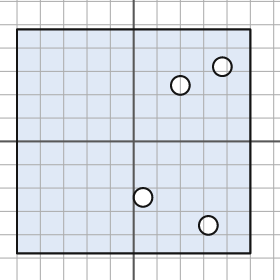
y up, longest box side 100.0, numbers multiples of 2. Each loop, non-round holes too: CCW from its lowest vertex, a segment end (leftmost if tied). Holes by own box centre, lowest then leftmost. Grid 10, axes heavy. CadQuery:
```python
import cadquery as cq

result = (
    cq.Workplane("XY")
    .moveTo(-50.0, -48.0)
    .lineTo(50.0, -48.0)
    .lineTo(50.0, 48.0)
    .lineTo(-50.0, 48.0)
    .close()
    .moveTo(32.0, -36.0)
    .circle(4.0)
    .moveTo(4.0, -24.0)
    .circle(4.0)
    .moveTo(20.0, 24.0)
    .circle(4.0)
    .moveTo(38.0, 32.0)
    .circle(4.0)
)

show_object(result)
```